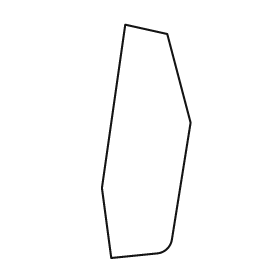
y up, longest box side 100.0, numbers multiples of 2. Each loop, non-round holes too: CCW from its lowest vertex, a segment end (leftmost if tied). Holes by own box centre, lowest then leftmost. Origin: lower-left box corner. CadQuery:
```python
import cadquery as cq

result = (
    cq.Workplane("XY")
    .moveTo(4.0, 0.0)
    .lineTo(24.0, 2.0)
    .threePointArc((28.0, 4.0), (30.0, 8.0))
    .lineTo(38.0, 58.0)
    .lineTo(28.0, 96.0)
    .lineTo(10.0, 100.0)
    .lineTo(0.0, 30.0)
    .close()
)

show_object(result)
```